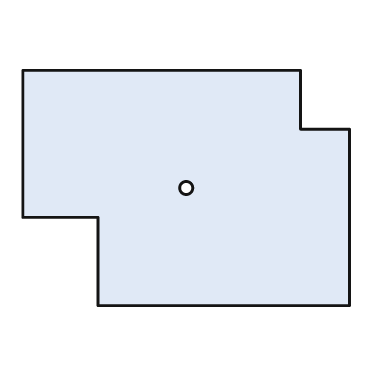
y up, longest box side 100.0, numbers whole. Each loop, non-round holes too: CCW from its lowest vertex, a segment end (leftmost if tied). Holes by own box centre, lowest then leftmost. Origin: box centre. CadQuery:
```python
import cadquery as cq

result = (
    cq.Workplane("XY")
    .moveTo(-27.0, -36.0)
    .lineTo(50.0, -36.0)
    .lineTo(50.0, 18.0)
    .lineTo(35.0, 18.0)
    .lineTo(35.0, 36.0)
    .lineTo(-50.0, 36.0)
    .lineTo(-50.0, -9.0)
    .lineTo(-27.0, -9.0)
    .close()
    .moveTo(0.0, 0.0)
    .circle(2.0)
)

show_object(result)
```